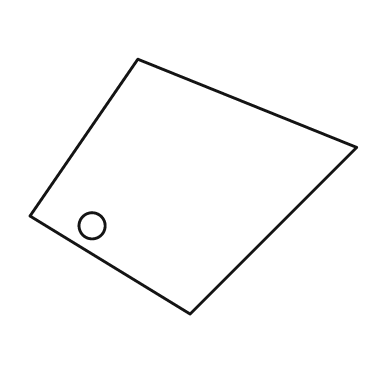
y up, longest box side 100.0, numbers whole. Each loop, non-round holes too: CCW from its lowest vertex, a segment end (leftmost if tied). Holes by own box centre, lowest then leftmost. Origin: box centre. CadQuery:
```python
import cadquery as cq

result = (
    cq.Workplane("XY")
    .moveTo(-1.0, -39.0)
    .lineTo(50.0, 12.0)
    .lineTo(-17.0, 39.0)
    .lineTo(-50.0, -9.0)
    .close()
    .moveTo(-31.0, -12.0)
    .circle(4.0)
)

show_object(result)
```